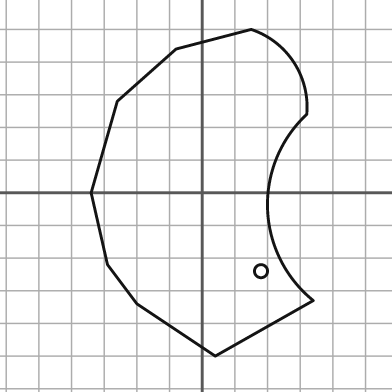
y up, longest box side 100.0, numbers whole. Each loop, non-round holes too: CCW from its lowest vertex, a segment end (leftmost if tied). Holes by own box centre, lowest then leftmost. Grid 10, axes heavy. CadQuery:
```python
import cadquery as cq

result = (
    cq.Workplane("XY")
    .moveTo(4.0, -50.0)
    .lineTo(34.0, -33.0)
    .threePointArc((20.0, -5.0), (32.0, 24.0))
    .threePointArc((28.0, 40.0), (15.0, 50.0))
    .lineTo(-8.0, 44.0)
    .lineTo(-26.0, 28.0)
    .lineTo(-34.0, 0.0)
    .lineTo(-29.0, -22.0)
    .lineTo(-20.0, -34.0)
    .close()
    .moveTo(18.0, -24.0)
    .circle(2.0)
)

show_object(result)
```